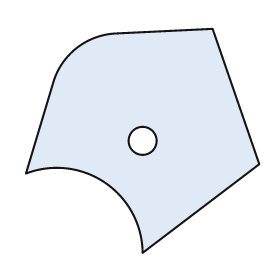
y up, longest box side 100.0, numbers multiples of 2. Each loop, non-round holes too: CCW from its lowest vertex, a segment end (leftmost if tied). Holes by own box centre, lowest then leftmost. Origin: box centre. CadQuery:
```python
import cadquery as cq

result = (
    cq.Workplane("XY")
    .moveTo(0.0, -48.0)
    .lineTo(50.0, -10.0)
    .lineTo(30.0, 48.0)
    .lineTo(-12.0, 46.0)
    .threePointArc((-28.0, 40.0), (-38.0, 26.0))
    .lineTo(-50.0, -14.0)
    .threePointArc((-16.0, -18.0), (0.0, -48.0))
    .close()
    .moveTo(0.0, 0.0)
    .circle(6.0)
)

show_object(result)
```